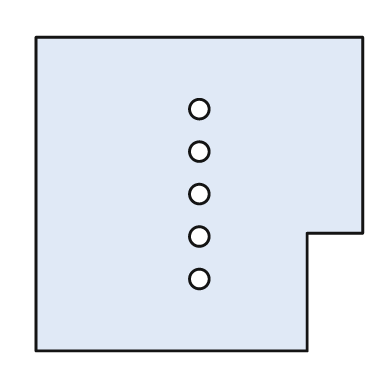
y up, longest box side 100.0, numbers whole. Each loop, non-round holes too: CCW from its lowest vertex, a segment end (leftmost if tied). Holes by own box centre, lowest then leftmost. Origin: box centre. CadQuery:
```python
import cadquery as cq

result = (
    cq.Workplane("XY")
    .moveTo(-50.0, -48.0)
    .lineTo(33.0, -48.0)
    .lineTo(33.0, -12.0)
    .lineTo(50.0, -12.0)
    .lineTo(50.0, 48.0)
    .lineTo(-50.0, 48.0)
    .close()
    .moveTo(0.0, -26.0)
    .circle(3.0)
    .moveTo(0.0, -13.0)
    .circle(3.0)
    .moveTo(0.0, 0.0)
    .circle(3.0)
    .moveTo(0.0, 13.0)
    .circle(3.0)
    .moveTo(0.0, 26.0)
    .circle(3.0)
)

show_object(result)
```